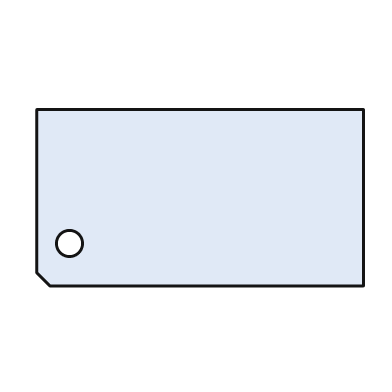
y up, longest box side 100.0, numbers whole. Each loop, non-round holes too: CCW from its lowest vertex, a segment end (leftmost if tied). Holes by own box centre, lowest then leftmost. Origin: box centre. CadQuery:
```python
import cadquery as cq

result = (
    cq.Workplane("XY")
    .moveTo(-46.0, -27.0)
    .lineTo(50.0, -27.0)
    .lineTo(50.0, 27.0)
    .lineTo(-50.0, 27.0)
    .lineTo(-50.0, -23.0)
    .close()
    .moveTo(-40.0, -14.0)
    .circle(4.0)
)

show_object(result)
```